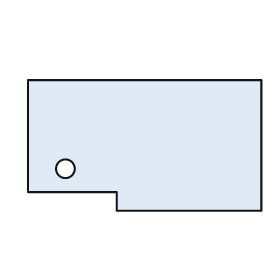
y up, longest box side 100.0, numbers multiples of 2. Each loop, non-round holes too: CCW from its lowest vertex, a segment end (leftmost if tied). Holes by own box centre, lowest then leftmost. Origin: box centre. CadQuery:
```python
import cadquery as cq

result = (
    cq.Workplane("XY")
    .moveTo(-12.0, -28.0)
    .lineTo(50.0, -28.0)
    .lineTo(50.0, 28.0)
    .lineTo(-50.0, 28.0)
    .lineTo(-50.0, -20.0)
    .lineTo(-12.0, -20.0)
    .close()
    .moveTo(-34.0, -10.0)
    .circle(4.0)
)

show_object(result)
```